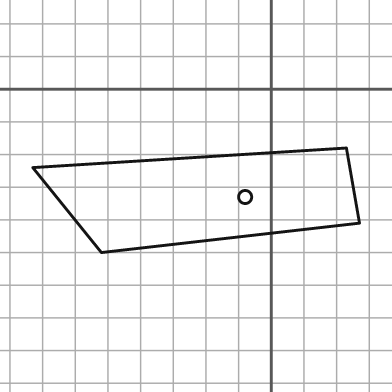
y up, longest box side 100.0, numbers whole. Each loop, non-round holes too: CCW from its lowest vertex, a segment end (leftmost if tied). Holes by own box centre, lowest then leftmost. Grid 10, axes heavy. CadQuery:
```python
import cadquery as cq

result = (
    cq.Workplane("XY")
    .moveTo(-52.0, -50.0)
    .lineTo(27.0, -41.0)
    .lineTo(23.0, -18.0)
    .lineTo(-73.0, -24.0)
    .close()
    .moveTo(-8.0, -33.0)
    .circle(2.0)
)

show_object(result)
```